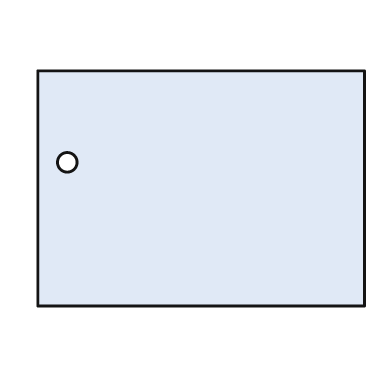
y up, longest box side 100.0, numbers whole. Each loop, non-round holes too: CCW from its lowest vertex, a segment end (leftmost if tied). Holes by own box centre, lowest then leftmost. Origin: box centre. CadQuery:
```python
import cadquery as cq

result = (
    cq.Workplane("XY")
    .moveTo(-50.0, -36.0)
    .lineTo(50.0, -36.0)
    .lineTo(50.0, 36.0)
    .lineTo(-50.0, 36.0)
    .close()
    .moveTo(-41.0, 8.0)
    .circle(3.0)
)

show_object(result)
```